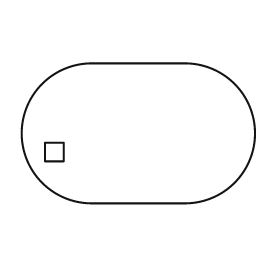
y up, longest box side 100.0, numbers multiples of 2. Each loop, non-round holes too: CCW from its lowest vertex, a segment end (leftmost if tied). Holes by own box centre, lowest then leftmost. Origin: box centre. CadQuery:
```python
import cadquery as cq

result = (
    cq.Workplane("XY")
    .moveTo(-20.0, -30.0)
    .lineTo(20.0, -30.0)
    .threePointArc((50.0, 0.0), (20.0, 30.0))
    .lineTo(-20.0, 30.0)
    .threePointArc((-50.0, 0.0), (-20.0, -30.0))
    .close()
    .moveTo(-40.0, -12.0)
    .lineTo(-32.0, -12.0)
    .lineTo(-32.0, -4.0)
    .lineTo(-40.0, -4.0)
    .close()
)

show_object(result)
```